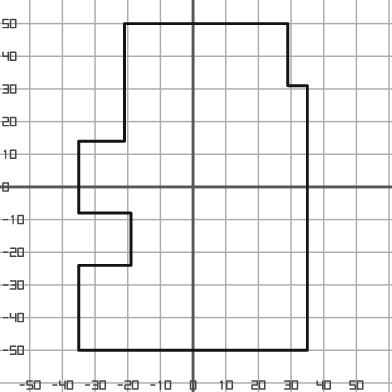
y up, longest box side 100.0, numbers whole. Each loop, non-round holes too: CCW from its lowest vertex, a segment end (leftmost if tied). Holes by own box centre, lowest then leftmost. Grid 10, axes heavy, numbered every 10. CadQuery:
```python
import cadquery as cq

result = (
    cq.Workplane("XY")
    .moveTo(-35.0, -50.0)
    .lineTo(35.0, -50.0)
    .lineTo(35.0, 31.0)
    .lineTo(29.0, 31.0)
    .lineTo(29.0, 50.0)
    .lineTo(-21.0, 50.0)
    .lineTo(-21.0, 14.0)
    .lineTo(-35.0, 14.0)
    .lineTo(-35.0, -8.0)
    .lineTo(-19.0, -8.0)
    .lineTo(-19.0, -24.0)
    .lineTo(-35.0, -24.0)
    .close()
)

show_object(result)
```